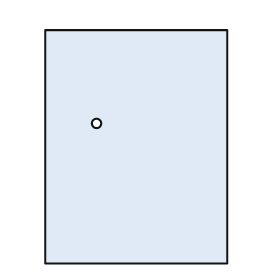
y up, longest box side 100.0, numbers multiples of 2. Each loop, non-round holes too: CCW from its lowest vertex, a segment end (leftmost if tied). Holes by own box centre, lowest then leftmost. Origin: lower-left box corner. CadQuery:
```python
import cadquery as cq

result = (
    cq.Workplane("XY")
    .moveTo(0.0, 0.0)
    .lineTo(78.0, 0.0)
    .lineTo(78.0, 100.0)
    .lineTo(0.0, 100.0)
    .close()
    .moveTo(22.0, 60.0)
    .circle(2.0)
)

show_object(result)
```